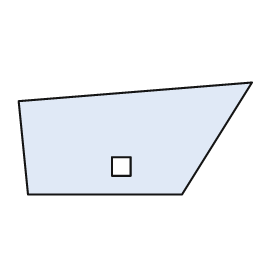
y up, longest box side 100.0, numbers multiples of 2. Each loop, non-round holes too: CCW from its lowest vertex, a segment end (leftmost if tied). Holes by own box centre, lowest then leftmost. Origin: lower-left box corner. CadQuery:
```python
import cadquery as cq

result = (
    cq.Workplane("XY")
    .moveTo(4.0, 0.0)
    .lineTo(70.0, 0.0)
    .lineTo(100.0, 48.0)
    .lineTo(0.0, 40.0)
    .close()
    .moveTo(40.0, 8.0)
    .lineTo(48.0, 8.0)
    .lineTo(48.0, 16.0)
    .lineTo(40.0, 16.0)
    .close()
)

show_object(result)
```